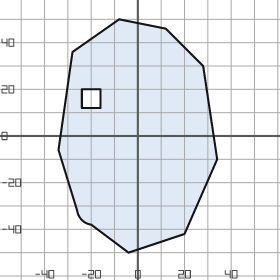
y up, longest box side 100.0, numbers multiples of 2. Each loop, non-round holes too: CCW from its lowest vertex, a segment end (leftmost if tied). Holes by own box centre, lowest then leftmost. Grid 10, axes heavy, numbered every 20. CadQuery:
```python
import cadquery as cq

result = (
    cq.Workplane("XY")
    .moveTo(-4.0, -50.0)
    .lineTo(20.0, -42.0)
    .lineTo(34.0, -10.0)
    .lineTo(28.0, 30.0)
    .lineTo(12.0, 46.0)
    .lineTo(-8.0, 50.0)
    .lineTo(-28.0, 36.0)
    .lineTo(-34.0, -6.0)
    .lineTo(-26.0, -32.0)
    .threePointArc((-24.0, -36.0), (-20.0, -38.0))
    .close()
    .moveTo(-24.0, 12.0)
    .lineTo(-16.0, 12.0)
    .lineTo(-16.0, 20.0)
    .lineTo(-24.0, 20.0)
    .close()
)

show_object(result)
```